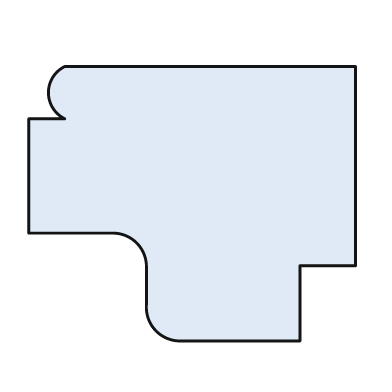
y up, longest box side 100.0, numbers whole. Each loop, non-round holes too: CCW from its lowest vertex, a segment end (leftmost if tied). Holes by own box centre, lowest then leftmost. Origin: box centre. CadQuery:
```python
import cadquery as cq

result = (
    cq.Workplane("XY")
    .moveTo(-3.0, -42.0)
    .lineTo(33.0, -42.0)
    .lineTo(33.0, -19.0)
    .lineTo(50.0, -19.0)
    .lineTo(50.0, 42.0)
    .lineTo(-39.0, 42.0)
    .threePointArc((-44.0, 34.0), (-39.0, 26.0))
    .lineTo(-50.0, 26.0)
    .lineTo(-50.0, -9.0)
    .lineTo(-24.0, -9.0)
    .threePointArc((-17.0, -12.0), (-14.0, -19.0))
    .lineTo(-14.0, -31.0)
    .threePointArc((-11.0, -39.0), (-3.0, -42.0))
    .close()
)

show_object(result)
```